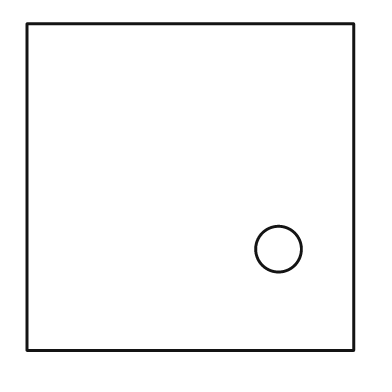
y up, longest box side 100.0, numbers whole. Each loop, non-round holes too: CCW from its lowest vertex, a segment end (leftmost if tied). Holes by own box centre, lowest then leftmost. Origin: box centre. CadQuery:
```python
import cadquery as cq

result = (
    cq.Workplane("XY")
    .moveTo(-50.0, -50.0)
    .lineTo(50.0, -50.0)
    .lineTo(50.0, 50.0)
    .lineTo(-50.0, 50.0)
    .close()
    .moveTo(27.0, -19.0)
    .circle(7.0)
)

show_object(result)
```